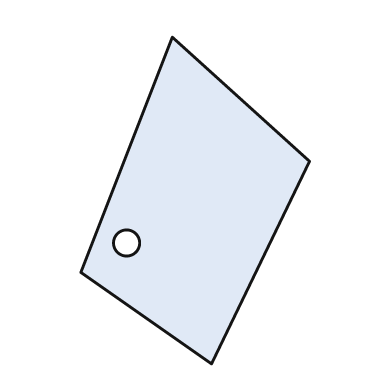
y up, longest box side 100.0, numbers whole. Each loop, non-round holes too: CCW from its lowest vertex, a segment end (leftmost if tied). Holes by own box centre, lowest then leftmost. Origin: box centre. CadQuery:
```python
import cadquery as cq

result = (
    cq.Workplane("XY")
    .moveTo(5.0, -50.0)
    .lineTo(35.0, 12.0)
    .lineTo(-7.0, 50.0)
    .lineTo(-35.0, -22.0)
    .close()
    .moveTo(-21.0, -13.0)
    .circle(4.0)
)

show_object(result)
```